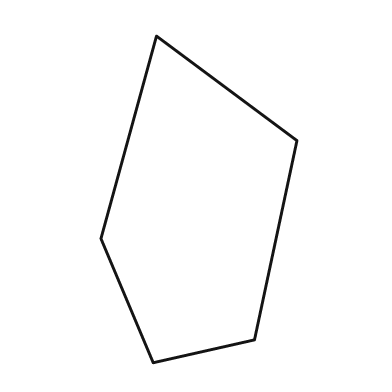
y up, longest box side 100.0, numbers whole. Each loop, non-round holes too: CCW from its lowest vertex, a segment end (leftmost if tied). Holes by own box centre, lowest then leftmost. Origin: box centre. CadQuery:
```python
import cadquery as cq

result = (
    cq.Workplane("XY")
    .moveTo(-14.0, -50.0)
    .lineTo(17.0, -43.0)
    .lineTo(30.0, 18.0)
    .lineTo(-13.0, 50.0)
    .lineTo(-30.0, -12.0)
    .close()
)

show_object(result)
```